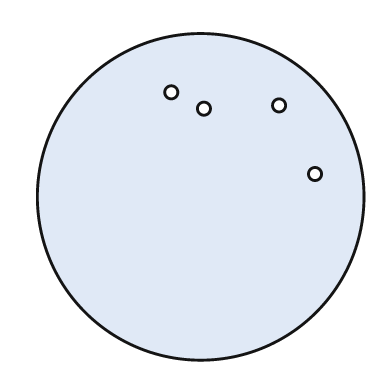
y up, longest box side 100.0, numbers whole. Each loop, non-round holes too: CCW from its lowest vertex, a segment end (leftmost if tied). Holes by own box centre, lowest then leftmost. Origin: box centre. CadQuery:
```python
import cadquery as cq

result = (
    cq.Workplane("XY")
    .moveTo(0.0, 0.0)
    .circle(50.0)
    .moveTo(35.0, 7.0)
    .circle(2.0)
    .moveTo(1.0, 27.0)
    .circle(2.0)
    .moveTo(24.0, 28.0)
    .circle(2.0)
    .moveTo(-9.0, 32.0)
    .circle(2.0)
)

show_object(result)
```